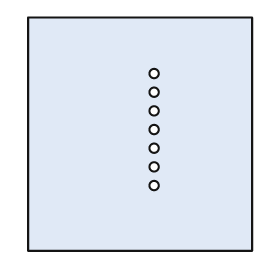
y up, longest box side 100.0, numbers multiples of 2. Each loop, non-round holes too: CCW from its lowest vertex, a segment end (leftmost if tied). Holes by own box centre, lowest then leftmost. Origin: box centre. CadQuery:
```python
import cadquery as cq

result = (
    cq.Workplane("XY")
    .moveTo(-48.0, -50.0)
    .lineTo(48.0, -50.0)
    .lineTo(48.0, 50.0)
    .lineTo(-48.0, 50.0)
    .close()
    .moveTo(6.0, -22.0)
    .circle(2.0)
    .moveTo(6.0, -14.0)
    .circle(2.0)
    .moveTo(6.0, -6.0)
    .circle(2.0)
    .moveTo(6.0, 2.0)
    .circle(2.0)
    .moveTo(6.0, 10.0)
    .circle(2.0)
    .moveTo(6.0, 18.0)
    .circle(2.0)
    .moveTo(6.0, 26.0)
    .circle(2.0)
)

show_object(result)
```